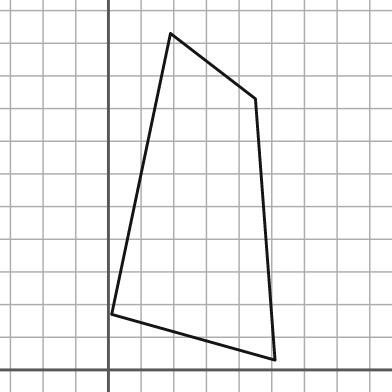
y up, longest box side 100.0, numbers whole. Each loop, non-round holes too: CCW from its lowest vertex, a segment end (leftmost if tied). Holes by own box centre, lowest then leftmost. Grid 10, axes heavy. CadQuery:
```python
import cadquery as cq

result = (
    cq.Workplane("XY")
    .moveTo(51.0, 3.0)
    .lineTo(45.0, 83.0)
    .lineTo(19.0, 103.0)
    .lineTo(1.0, 17.0)
    .close()
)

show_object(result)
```